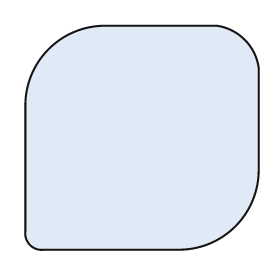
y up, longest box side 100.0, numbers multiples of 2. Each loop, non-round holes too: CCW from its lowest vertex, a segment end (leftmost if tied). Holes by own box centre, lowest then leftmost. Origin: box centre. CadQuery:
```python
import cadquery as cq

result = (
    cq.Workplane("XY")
    .moveTo(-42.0, -48.0)
    .lineTo(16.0, -48.0)
    .threePointArc((40.0, -38.0), (50.0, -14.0))
    .lineTo(50.0, 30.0)
    .threePointArc((44.0, 42.0), (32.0, 48.0))
    .lineTo(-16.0, 48.0)
    .threePointArc((-40.0, 38.0), (-50.0, 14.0))
    .lineTo(-50.0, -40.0)
    .threePointArc((-48.0, -46.0), (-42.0, -48.0))
    .close()
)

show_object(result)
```